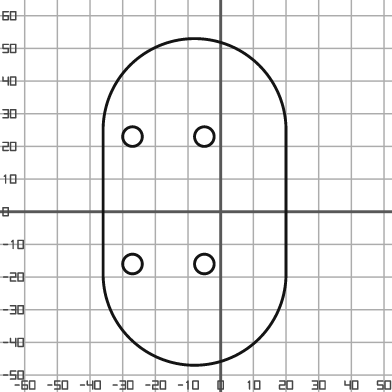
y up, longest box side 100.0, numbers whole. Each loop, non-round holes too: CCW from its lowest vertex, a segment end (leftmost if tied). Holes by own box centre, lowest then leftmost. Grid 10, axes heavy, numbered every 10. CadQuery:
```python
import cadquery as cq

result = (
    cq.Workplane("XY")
    .moveTo(-36.0, -19.0)
    .threePointArc((-8.0, -47.0), (20.0, -19.0))
    .lineTo(20.0, 25.0)
    .threePointArc((-8.0, 53.0), (-36.0, 25.0))
    .close()
    .moveTo(-27.0, -16.0)
    .circle(3.0)
    .moveTo(-5.0, -16.0)
    .circle(3.0)
    .moveTo(-27.0, 23.0)
    .circle(3.0)
    .moveTo(-5.0, 23.0)
    .circle(3.0)
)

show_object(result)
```